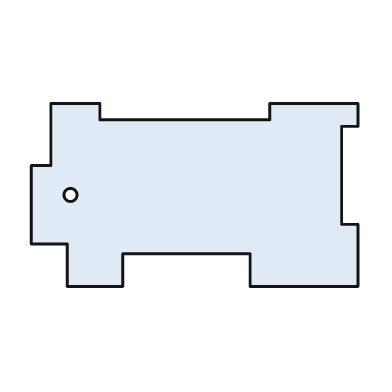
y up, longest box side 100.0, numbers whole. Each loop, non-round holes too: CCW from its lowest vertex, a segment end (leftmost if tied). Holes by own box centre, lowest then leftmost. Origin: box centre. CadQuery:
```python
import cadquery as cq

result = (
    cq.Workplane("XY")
    .moveTo(-39.0, -28.0)
    .lineTo(-22.0, -28.0)
    .lineTo(-22.0, -18.0)
    .lineTo(17.0, -18.0)
    .lineTo(17.0, -28.0)
    .lineTo(50.0, -28.0)
    .lineTo(50.0, -9.0)
    .lineTo(45.0, -9.0)
    .lineTo(45.0, 21.0)
    .lineTo(50.0, 21.0)
    .lineTo(50.0, 28.0)
    .lineTo(23.0, 28.0)
    .lineTo(23.0, 23.0)
    .lineTo(-29.0, 23.0)
    .lineTo(-29.0, 28.0)
    .lineTo(-44.0, 28.0)
    .lineTo(-44.0, 9.0)
    .lineTo(-50.0, 9.0)
    .lineTo(-50.0, -15.0)
    .lineTo(-39.0, -15.0)
    .close()
    .moveTo(-38.0, 0.0)
    .circle(2.0)
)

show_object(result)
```